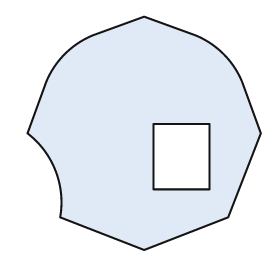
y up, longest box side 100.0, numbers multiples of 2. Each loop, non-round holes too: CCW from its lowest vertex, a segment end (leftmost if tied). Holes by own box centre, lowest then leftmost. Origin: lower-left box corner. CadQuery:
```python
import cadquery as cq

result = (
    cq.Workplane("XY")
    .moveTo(50.0, 0.0)
    .lineTo(86.0, 14.0)
    .lineTo(100.0, 50.0)
    .lineTo(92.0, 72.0)
    .threePointArc((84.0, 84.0), (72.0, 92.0))
    .lineTo(50.0, 100.0)
    .lineTo(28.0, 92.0)
    .threePointArc((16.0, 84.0), (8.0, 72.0))
    .lineTo(0.0, 50.0)
    .threePointArc((12.0, 34.0), (14.0, 14.0))
    .close()
    .moveTo(54.0, 26.0)
    .lineTo(78.0, 26.0)
    .lineTo(78.0, 54.0)
    .lineTo(54.0, 54.0)
    .close()
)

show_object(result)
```